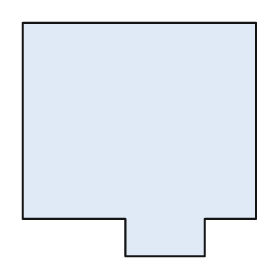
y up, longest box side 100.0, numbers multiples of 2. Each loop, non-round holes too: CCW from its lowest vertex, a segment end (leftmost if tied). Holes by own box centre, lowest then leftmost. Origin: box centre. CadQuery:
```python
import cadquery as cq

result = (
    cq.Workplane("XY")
    .moveTo(-6.0, -50.0)
    .lineTo(28.0, -50.0)
    .lineTo(28.0, -34.0)
    .lineTo(50.0, -34.0)
    .lineTo(50.0, 50.0)
    .lineTo(-50.0, 50.0)
    .lineTo(-50.0, -34.0)
    .lineTo(-6.0, -34.0)
    .close()
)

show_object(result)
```